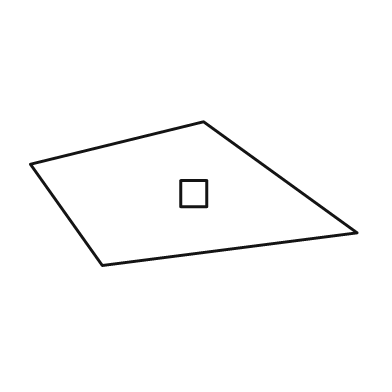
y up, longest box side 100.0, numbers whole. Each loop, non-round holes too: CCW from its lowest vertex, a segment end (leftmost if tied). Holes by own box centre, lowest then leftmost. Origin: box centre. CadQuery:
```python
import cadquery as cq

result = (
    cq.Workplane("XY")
    .moveTo(-28.0, -22.0)
    .lineTo(50.0, -12.0)
    .lineTo(3.0, 22.0)
    .lineTo(-50.0, 9.0)
    .close()
    .moveTo(-4.0, -4.0)
    .lineTo(4.0, -4.0)
    .lineTo(4.0, 4.0)
    .lineTo(-4.0, 4.0)
    .close()
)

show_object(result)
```